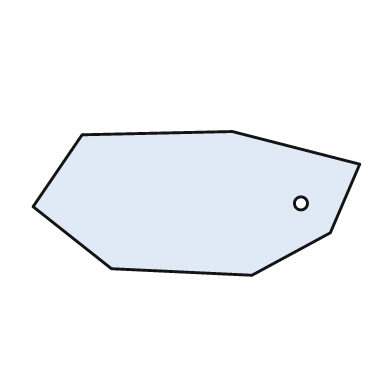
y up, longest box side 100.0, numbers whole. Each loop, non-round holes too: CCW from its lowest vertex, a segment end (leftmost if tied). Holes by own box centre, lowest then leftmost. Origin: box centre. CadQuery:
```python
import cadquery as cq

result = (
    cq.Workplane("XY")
    .moveTo(17.0, -22.0)
    .lineTo(41.0, -9.0)
    .lineTo(50.0, 12.0)
    .lineTo(11.0, 22.0)
    .lineTo(-35.0, 21.0)
    .lineTo(-50.0, -1.0)
    .lineTo(-26.0, -20.0)
    .close()
    .moveTo(32.0, 0.0)
    .circle(2.0)
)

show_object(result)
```